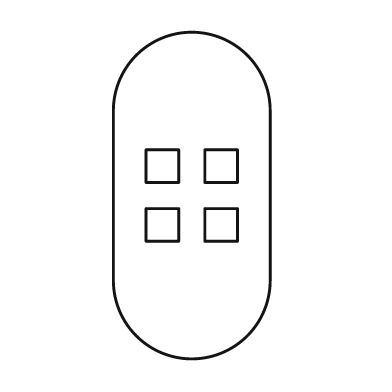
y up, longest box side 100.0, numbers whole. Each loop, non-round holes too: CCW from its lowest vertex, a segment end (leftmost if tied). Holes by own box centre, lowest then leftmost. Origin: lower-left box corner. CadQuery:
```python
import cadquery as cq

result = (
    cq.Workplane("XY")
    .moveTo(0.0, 24.0)
    .threePointArc((24.0, 0.0), (48.0, 24.0))
    .lineTo(48.0, 76.0)
    .threePointArc((24.0, 100.0), (0.0, 76.0))
    .close()
    .moveTo(10.0, 36.0)
    .lineTo(20.0, 36.0)
    .lineTo(20.0, 46.0)
    .lineTo(10.0, 46.0)
    .close()
    .moveTo(28.0, 36.0)
    .lineTo(38.0, 36.0)
    .lineTo(38.0, 46.0)
    .lineTo(28.0, 46.0)
    .close()
    .moveTo(10.0, 54.0)
    .lineTo(20.0, 54.0)
    .lineTo(20.0, 64.0)
    .lineTo(10.0, 64.0)
    .close()
    .moveTo(28.0, 54.0)
    .lineTo(38.0, 54.0)
    .lineTo(38.0, 64.0)
    .lineTo(28.0, 64.0)
    .close()
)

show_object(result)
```